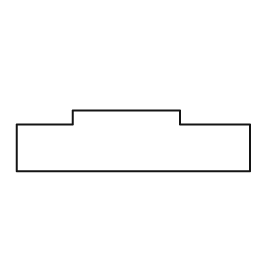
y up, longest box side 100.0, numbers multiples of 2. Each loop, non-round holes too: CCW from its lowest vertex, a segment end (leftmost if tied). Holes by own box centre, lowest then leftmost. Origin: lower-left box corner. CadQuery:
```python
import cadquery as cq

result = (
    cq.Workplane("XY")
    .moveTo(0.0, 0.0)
    .lineTo(100.0, 0.0)
    .lineTo(100.0, 20.0)
    .lineTo(70.0, 20.0)
    .lineTo(70.0, 26.0)
    .lineTo(24.0, 26.0)
    .lineTo(24.0, 20.0)
    .lineTo(0.0, 20.0)
    .close()
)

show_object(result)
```